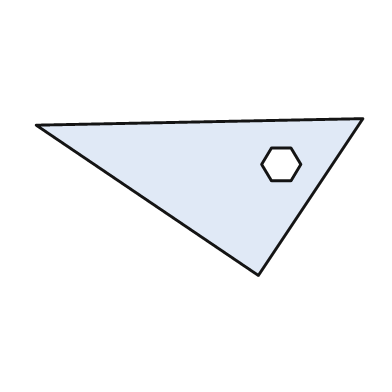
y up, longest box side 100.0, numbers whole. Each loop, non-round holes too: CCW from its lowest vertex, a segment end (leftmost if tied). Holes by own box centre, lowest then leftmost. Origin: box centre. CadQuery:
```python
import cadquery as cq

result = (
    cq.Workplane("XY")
    .moveTo(18.0, -24.0)
    .lineTo(50.0, 24.0)
    .lineTo(-50.0, 22.0)
    .close()
    .moveTo(22.0, 5.0)
    .lineTo(28.0, 5.0)
    .lineTo(31.0, 10.0)
    .lineTo(28.0, 15.0)
    .lineTo(22.0, 15.0)
    .lineTo(19.0, 10.0)
    .close()
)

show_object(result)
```